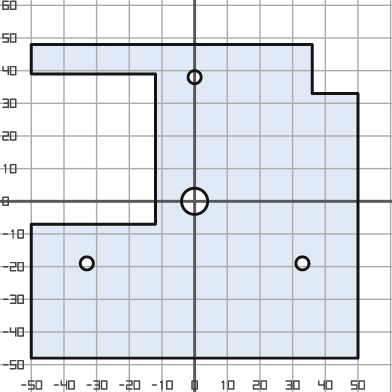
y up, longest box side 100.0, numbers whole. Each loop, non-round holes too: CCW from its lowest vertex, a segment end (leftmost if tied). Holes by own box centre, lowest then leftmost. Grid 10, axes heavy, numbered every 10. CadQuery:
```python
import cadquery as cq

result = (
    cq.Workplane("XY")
    .moveTo(-50.0, -48.0)
    .lineTo(50.0, -48.0)
    .lineTo(50.0, 33.0)
    .lineTo(36.0, 33.0)
    .lineTo(36.0, 48.0)
    .lineTo(-50.0, 48.0)
    .lineTo(-50.0, 39.0)
    .lineTo(-12.0, 39.0)
    .lineTo(-12.0, -7.0)
    .lineTo(-50.0, -7.0)
    .close()
    .moveTo(-33.0, -19.0)
    .circle(2.0)
    .moveTo(33.0, -19.0)
    .circle(2.0)
    .moveTo(0.0, 0.0)
    .circle(4.0)
    .moveTo(0.0, 38.0)
    .circle(2.0)
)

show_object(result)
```